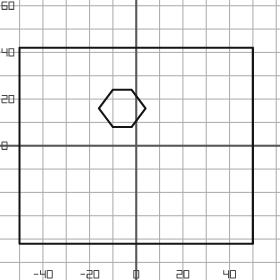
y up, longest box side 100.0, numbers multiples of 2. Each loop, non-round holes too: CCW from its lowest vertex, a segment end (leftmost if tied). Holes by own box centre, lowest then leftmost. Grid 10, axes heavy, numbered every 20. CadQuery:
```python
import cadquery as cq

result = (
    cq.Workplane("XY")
    .moveTo(-50.0, -42.0)
    .lineTo(50.0, -42.0)
    .lineTo(50.0, 42.0)
    .lineTo(-50.0, 42.0)
    .close()
    .moveTo(-10.0, 8.0)
    .lineTo(-2.0, 8.0)
    .lineTo(4.0, 16.0)
    .lineTo(-2.0, 24.0)
    .lineTo(-10.0, 24.0)
    .lineTo(-16.0, 16.0)
    .close()
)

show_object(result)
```